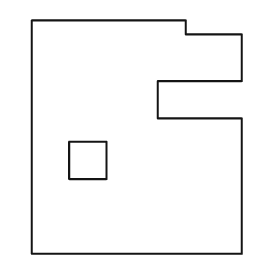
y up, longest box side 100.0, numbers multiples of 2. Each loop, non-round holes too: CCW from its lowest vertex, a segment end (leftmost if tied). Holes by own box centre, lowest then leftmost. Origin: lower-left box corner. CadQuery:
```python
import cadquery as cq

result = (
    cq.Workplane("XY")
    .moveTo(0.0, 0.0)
    .lineTo(90.0, 0.0)
    .lineTo(90.0, 58.0)
    .lineTo(54.0, 58.0)
    .lineTo(54.0, 74.0)
    .lineTo(90.0, 74.0)
    .lineTo(90.0, 94.0)
    .lineTo(66.0, 94.0)
    .lineTo(66.0, 100.0)
    .lineTo(0.0, 100.0)
    .close()
    .moveTo(16.0, 32.0)
    .lineTo(32.0, 32.0)
    .lineTo(32.0, 48.0)
    .lineTo(16.0, 48.0)
    .close()
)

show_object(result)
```